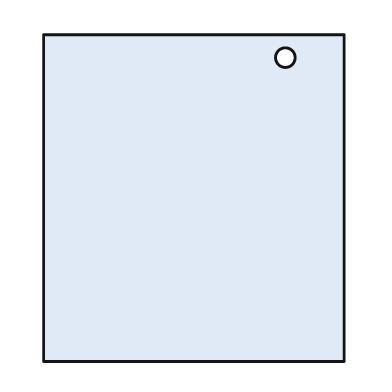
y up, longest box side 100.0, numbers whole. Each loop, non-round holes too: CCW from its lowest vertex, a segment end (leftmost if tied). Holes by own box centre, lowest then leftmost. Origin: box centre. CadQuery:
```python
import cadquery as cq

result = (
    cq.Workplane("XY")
    .moveTo(-46.0, -50.0)
    .lineTo(46.0, -50.0)
    .lineTo(46.0, 50.0)
    .lineTo(-46.0, 50.0)
    .close()
    .moveTo(28.0, 43.0)
    .circle(3.0)
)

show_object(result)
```